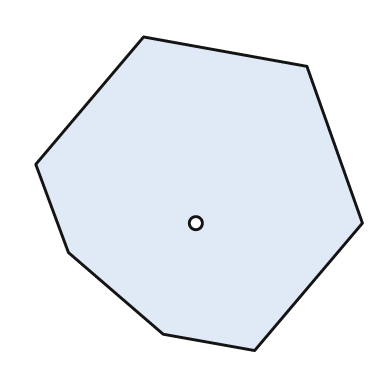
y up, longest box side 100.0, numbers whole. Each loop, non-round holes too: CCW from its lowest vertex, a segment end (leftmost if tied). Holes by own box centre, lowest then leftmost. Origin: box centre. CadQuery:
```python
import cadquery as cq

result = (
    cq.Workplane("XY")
    .moveTo(17.0, -48.0)
    .lineTo(50.0, -9.0)
    .lineTo(33.0, 39.0)
    .lineTo(-17.0, 48.0)
    .lineTo(-50.0, 9.0)
    .lineTo(-40.0, -18.0)
    .lineTo(-11.0, -43.0)
    .close()
    .moveTo(-1.0, -9.0)
    .circle(2.0)
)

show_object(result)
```